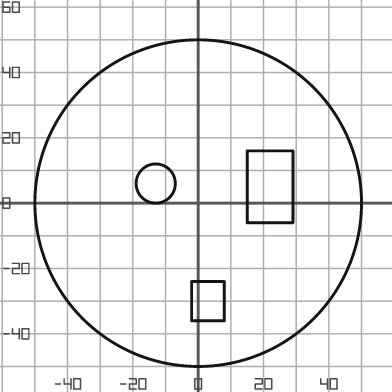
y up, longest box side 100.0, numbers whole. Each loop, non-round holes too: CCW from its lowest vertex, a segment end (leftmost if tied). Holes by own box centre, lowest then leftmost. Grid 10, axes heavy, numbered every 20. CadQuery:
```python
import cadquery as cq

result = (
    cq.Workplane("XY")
    .moveTo(0.0, 0.0)
    .circle(50.0)
    .moveTo(-2.0, -36.0)
    .lineTo(8.0, -36.0)
    .lineTo(8.0, -24.0)
    .lineTo(-2.0, -24.0)
    .close()
    .moveTo(15.0, -6.0)
    .lineTo(29.0, -6.0)
    .lineTo(29.0, 16.0)
    .lineTo(15.0, 16.0)
    .close()
    .moveTo(-13.0, 6.0)
    .circle(6.0)
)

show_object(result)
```